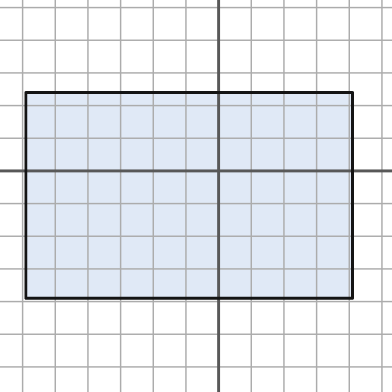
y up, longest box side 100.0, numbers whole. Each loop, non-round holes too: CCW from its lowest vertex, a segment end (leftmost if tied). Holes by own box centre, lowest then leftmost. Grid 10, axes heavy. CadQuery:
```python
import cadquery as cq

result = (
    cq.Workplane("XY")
    .moveTo(-59.0, -39.0)
    .lineTo(41.0, -39.0)
    .lineTo(41.0, 24.0)
    .lineTo(-59.0, 24.0)
    .close()
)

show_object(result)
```